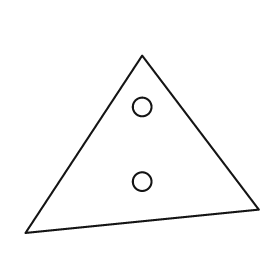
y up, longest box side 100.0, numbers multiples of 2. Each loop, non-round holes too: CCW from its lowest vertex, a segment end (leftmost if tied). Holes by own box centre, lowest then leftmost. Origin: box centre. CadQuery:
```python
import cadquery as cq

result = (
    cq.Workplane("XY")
    .moveTo(-50.0, -38.0)
    .lineTo(50.0, -28.0)
    .lineTo(0.0, 38.0)
    .close()
    .moveTo(0.0, -16.0)
    .circle(4.0)
    .moveTo(0.0, 16.0)
    .circle(4.0)
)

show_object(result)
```